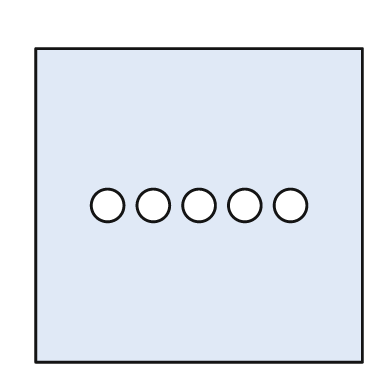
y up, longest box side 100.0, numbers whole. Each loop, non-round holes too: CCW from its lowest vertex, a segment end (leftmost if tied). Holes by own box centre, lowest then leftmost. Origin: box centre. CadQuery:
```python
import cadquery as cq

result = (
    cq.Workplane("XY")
    .moveTo(-50.0, -48.0)
    .lineTo(50.0, -48.0)
    .lineTo(50.0, 48.0)
    .lineTo(-50.0, 48.0)
    .close()
    .moveTo(-28.0, 0.0)
    .circle(5.0)
    .moveTo(-14.0, 0.0)
    .circle(5.0)
    .moveTo(0.0, 0.0)
    .circle(5.0)
    .moveTo(14.0, 0.0)
    .circle(5.0)
    .moveTo(28.0, 0.0)
    .circle(5.0)
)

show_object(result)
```